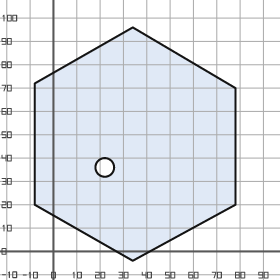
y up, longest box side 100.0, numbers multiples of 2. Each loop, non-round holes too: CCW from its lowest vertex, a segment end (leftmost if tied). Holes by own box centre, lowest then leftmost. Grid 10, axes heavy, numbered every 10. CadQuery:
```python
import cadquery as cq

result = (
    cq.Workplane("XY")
    .moveTo(34.0, -4.0)
    .lineTo(78.0, 20.0)
    .lineTo(78.0, 70.0)
    .lineTo(34.0, 96.0)
    .lineTo(-8.0, 72.0)
    .lineTo(-8.0, 20.0)
    .close()
    .moveTo(22.0, 36.0)
    .circle(4.0)
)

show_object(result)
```